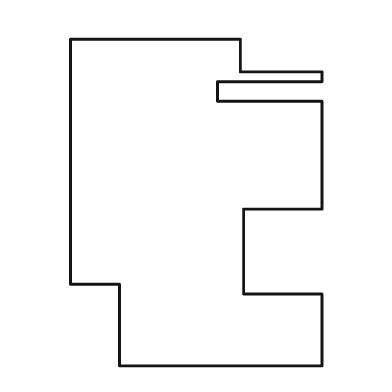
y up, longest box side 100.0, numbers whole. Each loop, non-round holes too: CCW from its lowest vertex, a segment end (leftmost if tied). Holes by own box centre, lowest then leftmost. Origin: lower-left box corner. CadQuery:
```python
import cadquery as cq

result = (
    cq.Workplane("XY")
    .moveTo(15.0, 0.0)
    .lineTo(77.0, 0.0)
    .lineTo(77.0, 22.0)
    .lineTo(53.0, 22.0)
    .lineTo(53.0, 48.0)
    .lineTo(77.0, 48.0)
    .lineTo(77.0, 81.0)
    .lineTo(45.0, 81.0)
    .lineTo(45.0, 87.0)
    .lineTo(77.0, 87.0)
    .lineTo(77.0, 90.0)
    .lineTo(52.0, 90.0)
    .lineTo(52.0, 100.0)
    .lineTo(0.0, 100.0)
    .lineTo(0.0, 25.0)
    .lineTo(15.0, 25.0)
    .close()
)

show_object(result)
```